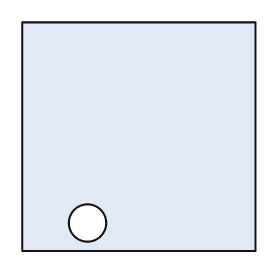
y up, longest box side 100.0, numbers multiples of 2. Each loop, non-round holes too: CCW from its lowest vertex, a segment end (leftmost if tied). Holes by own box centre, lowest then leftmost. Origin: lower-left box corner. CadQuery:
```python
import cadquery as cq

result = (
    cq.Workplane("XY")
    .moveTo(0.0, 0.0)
    .lineTo(100.0, 0.0)
    .lineTo(100.0, 98.0)
    .lineTo(0.0, 98.0)
    .close()
    .moveTo(28.0, 12.0)
    .circle(8.0)
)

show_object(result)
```